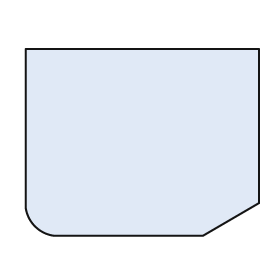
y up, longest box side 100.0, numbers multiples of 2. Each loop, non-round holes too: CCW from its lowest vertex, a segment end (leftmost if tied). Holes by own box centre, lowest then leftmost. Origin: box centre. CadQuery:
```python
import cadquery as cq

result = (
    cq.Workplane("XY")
    .moveTo(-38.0, -40.0)
    .lineTo(26.0, -40.0)
    .lineTo(50.0, -26.0)
    .lineTo(50.0, 40.0)
    .lineTo(-50.0, 40.0)
    .lineTo(-50.0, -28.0)
    .threePointArc((-46.0, -36.0), (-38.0, -40.0))
    .close()
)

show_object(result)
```